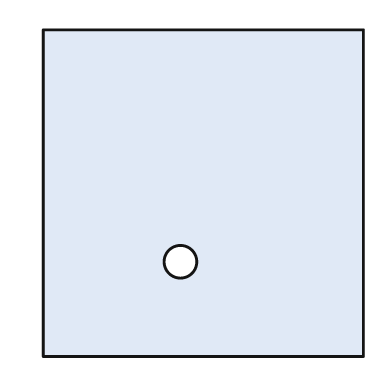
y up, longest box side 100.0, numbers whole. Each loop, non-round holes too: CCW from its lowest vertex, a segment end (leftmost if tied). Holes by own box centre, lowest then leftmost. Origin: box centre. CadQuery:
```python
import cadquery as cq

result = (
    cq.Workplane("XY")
    .moveTo(-49.0, -50.0)
    .lineTo(49.0, -50.0)
    .lineTo(49.0, 50.0)
    .lineTo(-49.0, 50.0)
    .close()
    .moveTo(-7.0, -21.0)
    .circle(5.0)
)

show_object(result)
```